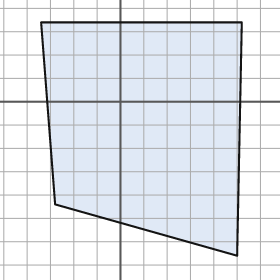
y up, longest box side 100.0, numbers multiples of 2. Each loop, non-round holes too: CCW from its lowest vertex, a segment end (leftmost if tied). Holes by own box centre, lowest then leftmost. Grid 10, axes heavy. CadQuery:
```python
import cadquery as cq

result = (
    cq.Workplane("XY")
    .moveTo(50.0, -66.0)
    .lineTo(52.0, 34.0)
    .lineTo(-34.0, 34.0)
    .lineTo(-28.0, -44.0)
    .close()
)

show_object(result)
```